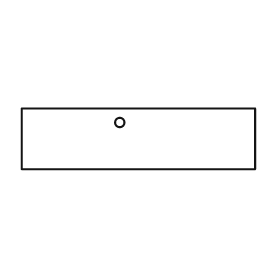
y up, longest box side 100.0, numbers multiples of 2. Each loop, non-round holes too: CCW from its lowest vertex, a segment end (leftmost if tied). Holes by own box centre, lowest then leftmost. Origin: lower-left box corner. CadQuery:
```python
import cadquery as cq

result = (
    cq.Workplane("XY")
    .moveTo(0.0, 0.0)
    .lineTo(100.0, 0.0)
    .lineTo(100.0, 26.0)
    .lineTo(0.0, 26.0)
    .close()
    .moveTo(42.0, 20.0)
    .circle(2.0)
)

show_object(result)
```